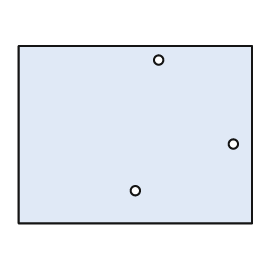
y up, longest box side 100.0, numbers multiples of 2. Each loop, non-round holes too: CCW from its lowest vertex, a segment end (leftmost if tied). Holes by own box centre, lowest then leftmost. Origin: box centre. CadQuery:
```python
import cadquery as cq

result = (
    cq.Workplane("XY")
    .moveTo(-50.0, -38.0)
    .lineTo(50.0, -38.0)
    .lineTo(50.0, 38.0)
    .lineTo(-50.0, 38.0)
    .close()
    .moveTo(0.0, -24.0)
    .circle(2.0)
    .moveTo(42.0, -4.0)
    .circle(2.0)
    .moveTo(10.0, 32.0)
    .circle(2.0)
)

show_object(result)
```